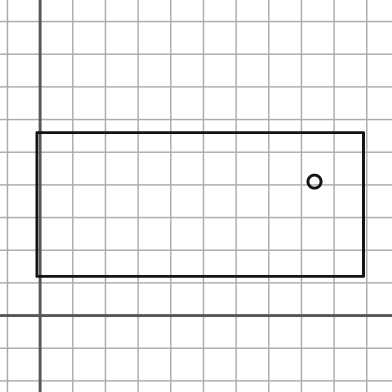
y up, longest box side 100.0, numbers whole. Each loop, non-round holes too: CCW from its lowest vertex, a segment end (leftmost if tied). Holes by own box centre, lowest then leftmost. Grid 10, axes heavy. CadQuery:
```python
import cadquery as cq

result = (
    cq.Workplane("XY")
    .moveTo(-1.0, 12.0)
    .lineTo(99.0, 12.0)
    .lineTo(99.0, 56.0)
    .lineTo(-1.0, 56.0)
    .close()
    .moveTo(84.0, 41.0)
    .circle(2.0)
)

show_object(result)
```